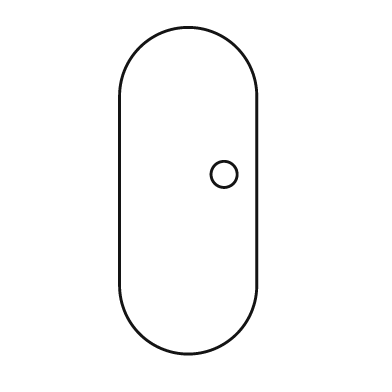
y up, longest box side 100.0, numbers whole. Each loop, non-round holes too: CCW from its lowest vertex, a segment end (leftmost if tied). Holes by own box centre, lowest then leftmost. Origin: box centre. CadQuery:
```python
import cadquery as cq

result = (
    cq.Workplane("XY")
    .moveTo(-21.0, -29.0)
    .threePointArc((0.0, -50.0), (21.0, -29.0))
    .lineTo(21.0, 29.0)
    .threePointArc((0.0, 50.0), (-21.0, 29.0))
    .close()
    .moveTo(11.0, 5.0)
    .circle(4.0)
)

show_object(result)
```